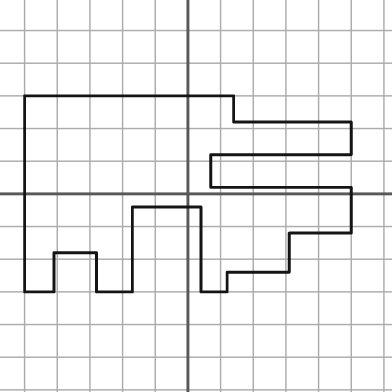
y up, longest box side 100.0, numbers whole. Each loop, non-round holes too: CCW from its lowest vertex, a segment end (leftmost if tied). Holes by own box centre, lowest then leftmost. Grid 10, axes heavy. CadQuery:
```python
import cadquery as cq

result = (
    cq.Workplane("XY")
    .moveTo(-50.0, -30.0)
    .lineTo(-41.0, -30.0)
    .lineTo(-41.0, -18.0)
    .lineTo(-28.0, -18.0)
    .lineTo(-28.0, -30.0)
    .lineTo(-17.0, -30.0)
    .lineTo(-17.0, -4.0)
    .lineTo(4.0, -4.0)
    .lineTo(4.0, -30.0)
    .lineTo(12.0, -30.0)
    .lineTo(12.0, -24.0)
    .lineTo(31.0, -24.0)
    .lineTo(31.0, -12.0)
    .lineTo(50.0, -12.0)
    .lineTo(50.0, 2.0)
    .lineTo(7.0, 2.0)
    .lineTo(7.0, 12.0)
    .lineTo(50.0, 12.0)
    .lineTo(50.0, 22.0)
    .lineTo(14.0, 22.0)
    .lineTo(14.0, 30.0)
    .lineTo(-50.0, 30.0)
    .close()
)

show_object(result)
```